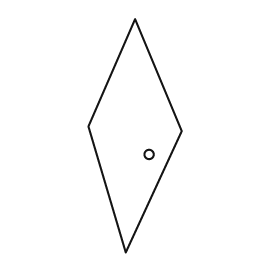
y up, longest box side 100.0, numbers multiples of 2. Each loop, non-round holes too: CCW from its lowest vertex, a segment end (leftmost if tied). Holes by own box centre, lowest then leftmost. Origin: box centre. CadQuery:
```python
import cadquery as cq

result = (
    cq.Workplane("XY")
    .moveTo(-4.0, -50.0)
    .lineTo(20.0, 2.0)
    .lineTo(0.0, 50.0)
    .lineTo(-20.0, 4.0)
    .close()
    .moveTo(6.0, -8.0)
    .circle(2.0)
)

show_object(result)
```